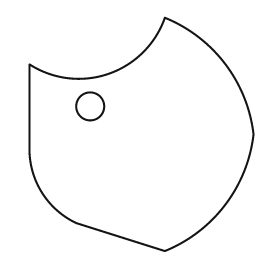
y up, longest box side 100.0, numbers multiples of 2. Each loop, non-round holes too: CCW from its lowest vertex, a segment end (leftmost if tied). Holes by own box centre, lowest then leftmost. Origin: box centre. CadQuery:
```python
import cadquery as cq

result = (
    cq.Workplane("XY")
    .moveTo(10.0, -50.0)
    .threePointArc((36.0, -30.0), (48.0, 0.0))
    .threePointArc((36.0, 30.0), (10.0, 50.0))
    .threePointArc((-14.0, 26.0), (-48.0, 30.0))
    .lineTo(-48.0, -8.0)
    .threePointArc((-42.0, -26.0), (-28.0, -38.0))
    .close()
    .moveTo(-22.0, 12.0)
    .circle(6.0)
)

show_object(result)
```